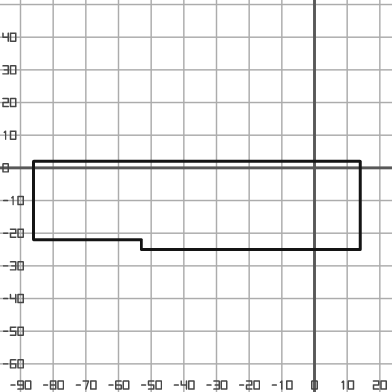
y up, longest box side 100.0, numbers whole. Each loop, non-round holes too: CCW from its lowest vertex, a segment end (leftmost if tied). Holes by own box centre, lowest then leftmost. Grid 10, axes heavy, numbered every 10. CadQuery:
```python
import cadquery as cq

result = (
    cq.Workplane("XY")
    .moveTo(-53.0, -25.0)
    .lineTo(14.0, -25.0)
    .lineTo(14.0, 2.0)
    .lineTo(-86.0, 2.0)
    .lineTo(-86.0, -22.0)
    .lineTo(-53.0, -22.0)
    .close()
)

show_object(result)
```